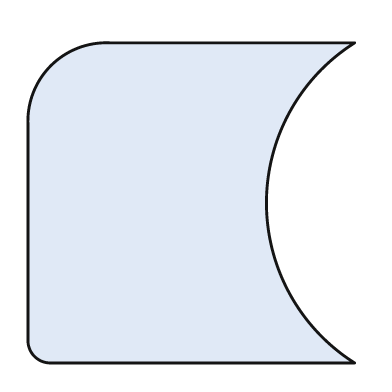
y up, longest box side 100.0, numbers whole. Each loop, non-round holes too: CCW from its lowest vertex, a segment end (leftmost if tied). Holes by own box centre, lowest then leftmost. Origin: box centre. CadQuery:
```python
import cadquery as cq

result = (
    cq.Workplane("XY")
    .moveTo(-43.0, -49.0)
    .lineTo(50.0, -49.0)
    .threePointArc((23.0, 0.0), (50.0, 49.0))
    .lineTo(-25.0, 49.0)
    .threePointArc((-43.0, 42.0), (-50.0, 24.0))
    .lineTo(-50.0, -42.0)
    .threePointArc((-48.0, -47.0), (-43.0, -49.0))
    .close()
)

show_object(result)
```